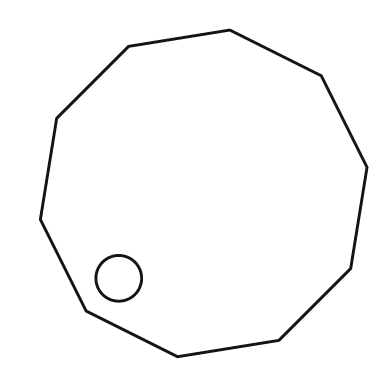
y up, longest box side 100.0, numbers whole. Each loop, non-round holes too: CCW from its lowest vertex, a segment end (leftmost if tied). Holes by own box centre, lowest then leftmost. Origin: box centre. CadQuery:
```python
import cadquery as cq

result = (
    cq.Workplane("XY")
    .moveTo(-8.0, -50.0)
    .lineTo(23.0, -45.0)
    .lineTo(45.0, -23.0)
    .lineTo(50.0, 8.0)
    .lineTo(36.0, 36.0)
    .lineTo(8.0, 50.0)
    .lineTo(-23.0, 45.0)
    .lineTo(-45.0, 23.0)
    .lineTo(-50.0, -8.0)
    .lineTo(-36.0, -36.0)
    .close()
    .moveTo(-26.0, -26.0)
    .circle(7.0)
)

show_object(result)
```